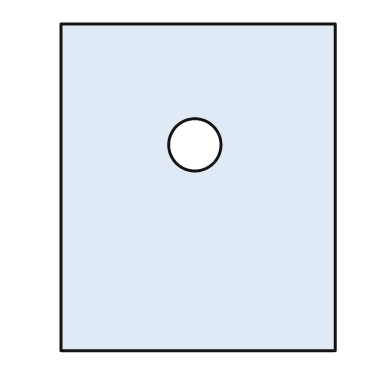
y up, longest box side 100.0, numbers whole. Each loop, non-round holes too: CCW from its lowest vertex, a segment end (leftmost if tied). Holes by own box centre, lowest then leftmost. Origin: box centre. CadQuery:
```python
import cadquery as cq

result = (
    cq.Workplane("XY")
    .moveTo(-42.0, -50.0)
    .lineTo(42.0, -50.0)
    .lineTo(42.0, 50.0)
    .lineTo(-42.0, 50.0)
    .close()
    .moveTo(-1.0, 13.0)
    .circle(8.0)
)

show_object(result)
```